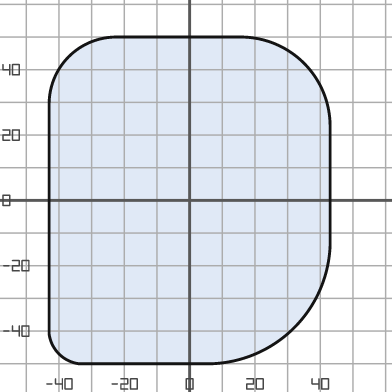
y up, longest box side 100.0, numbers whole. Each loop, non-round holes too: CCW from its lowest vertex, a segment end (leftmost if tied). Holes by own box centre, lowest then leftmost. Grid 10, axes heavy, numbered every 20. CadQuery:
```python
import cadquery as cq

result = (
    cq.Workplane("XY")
    .moveTo(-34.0, -50.0)
    .lineTo(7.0, -50.0)
    .threePointArc((32.0, -39.0), (43.0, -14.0))
    .lineTo(43.0, 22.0)
    .threePointArc((35.0, 42.0), (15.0, 50.0))
    .lineTo(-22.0, 50.0)
    .threePointArc((-37.0, 44.0), (-43.0, 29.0))
    .lineTo(-43.0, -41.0)
    .threePointArc((-40.0, -47.0), (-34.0, -50.0))
    .close()
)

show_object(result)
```